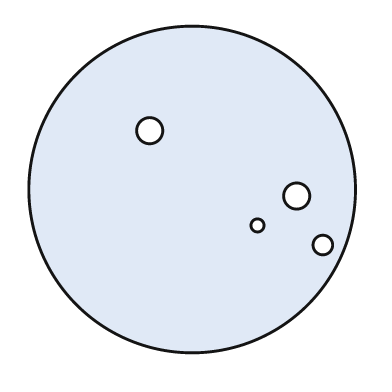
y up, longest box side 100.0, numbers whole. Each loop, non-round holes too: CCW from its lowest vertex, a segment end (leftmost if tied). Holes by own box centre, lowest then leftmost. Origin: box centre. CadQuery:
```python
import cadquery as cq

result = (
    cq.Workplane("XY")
    .moveTo(0.0, 0.0)
    .circle(50.0)
    .moveTo(40.0, -17.0)
    .circle(3.0)
    .moveTo(20.0, -11.0)
    .circle(2.0)
    .moveTo(32.0, -2.0)
    .circle(4.0)
    .moveTo(-13.0, 18.0)
    .circle(4.0)
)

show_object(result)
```